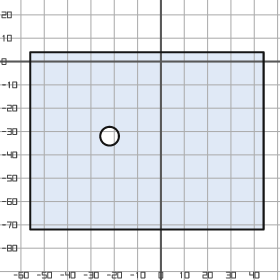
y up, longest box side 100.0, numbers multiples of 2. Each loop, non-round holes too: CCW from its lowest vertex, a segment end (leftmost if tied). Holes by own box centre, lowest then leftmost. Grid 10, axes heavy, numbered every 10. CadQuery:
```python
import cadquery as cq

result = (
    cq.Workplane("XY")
    .moveTo(-56.0, -72.0)
    .lineTo(44.0, -72.0)
    .lineTo(44.0, 4.0)
    .lineTo(-56.0, 4.0)
    .close()
    .moveTo(-22.0, -32.0)
    .circle(4.0)
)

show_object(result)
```